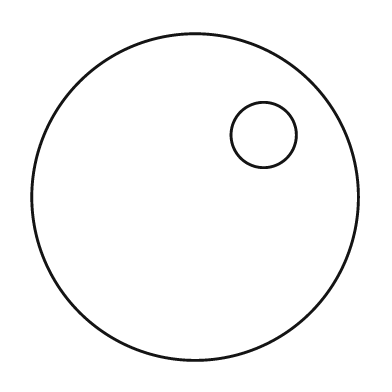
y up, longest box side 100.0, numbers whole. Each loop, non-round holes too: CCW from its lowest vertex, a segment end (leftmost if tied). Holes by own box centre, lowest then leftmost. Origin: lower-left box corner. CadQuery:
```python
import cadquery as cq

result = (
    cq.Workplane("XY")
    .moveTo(50.0, 50.0)
    .circle(50.0)
    .moveTo(71.0, 69.0)
    .circle(10.0)
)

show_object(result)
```